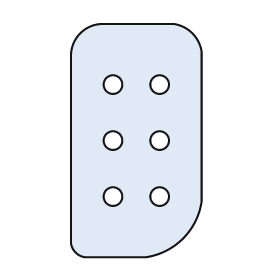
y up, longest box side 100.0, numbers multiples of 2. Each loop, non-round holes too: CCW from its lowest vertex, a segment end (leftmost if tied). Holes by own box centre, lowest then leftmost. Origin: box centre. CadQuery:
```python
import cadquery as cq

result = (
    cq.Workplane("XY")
    .moveTo(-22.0, -50.0)
    .lineTo(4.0, -50.0)
    .threePointArc((20.0, -42.0), (28.0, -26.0))
    .lineTo(28.0, 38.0)
    .threePointArc((24.0, 46.0), (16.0, 50.0))
    .lineTo(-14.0, 50.0)
    .threePointArc((-24.0, 46.0), (-28.0, 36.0))
    .lineTo(-28.0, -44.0)
    .threePointArc((-26.0, -48.0), (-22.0, -50.0))
    .close()
    .moveTo(-10.0, -24.0)
    .circle(4.0)
    .moveTo(10.0, -24.0)
    .circle(4.0)
    .moveTo(-10.0, 0.0)
    .circle(4.0)
    .moveTo(10.0, 0.0)
    .circle(4.0)
    .moveTo(-10.0, 24.0)
    .circle(4.0)
    .moveTo(10.0, 24.0)
    .circle(4.0)
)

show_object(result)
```